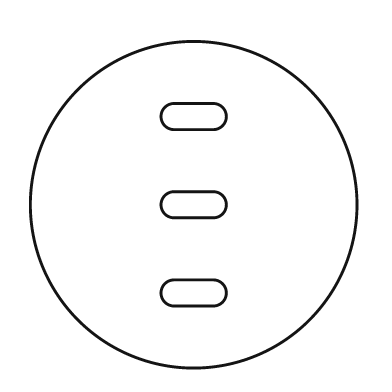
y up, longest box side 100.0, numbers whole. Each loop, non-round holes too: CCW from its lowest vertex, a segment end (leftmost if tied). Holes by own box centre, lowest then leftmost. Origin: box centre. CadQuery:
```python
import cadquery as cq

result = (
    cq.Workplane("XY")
    .moveTo(0.0, 0.0)
    .circle(50.0)
    .moveTo(-6.0, -31.0)
    .lineTo(6.0, -31.0)
    .threePointArc((10.0, -27.0), (6.0, -23.0))
    .lineTo(-6.0, -23.0)
    .threePointArc((-10.0, -27.0), (-6.0, -31.0))
    .close()
    .moveTo(-6.0, -4.0)
    .lineTo(6.0, -4.0)
    .threePointArc((10.0, 0.0), (6.0, 4.0))
    .lineTo(-6.0, 4.0)
    .threePointArc((-10.0, 0.0), (-6.0, -4.0))
    .close()
    .moveTo(-6.0, 23.0)
    .lineTo(6.0, 23.0)
    .threePointArc((10.0, 27.0), (6.0, 31.0))
    .lineTo(-6.0, 31.0)
    .threePointArc((-10.0, 27.0), (-6.0, 23.0))
    .close()
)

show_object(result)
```